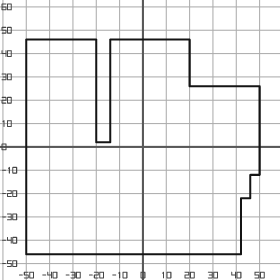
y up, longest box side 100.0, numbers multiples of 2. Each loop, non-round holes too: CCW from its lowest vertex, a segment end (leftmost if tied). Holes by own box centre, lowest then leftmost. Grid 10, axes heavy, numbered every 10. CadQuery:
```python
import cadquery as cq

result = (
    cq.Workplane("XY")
    .moveTo(-50.0, -46.0)
    .lineTo(42.0, -46.0)
    .lineTo(42.0, -22.0)
    .lineTo(46.0, -22.0)
    .lineTo(46.0, -12.0)
    .lineTo(50.0, -12.0)
    .lineTo(50.0, 26.0)
    .lineTo(20.0, 26.0)
    .lineTo(20.0, 46.0)
    .lineTo(-14.0, 46.0)
    .lineTo(-14.0, 2.0)
    .lineTo(-20.0, 2.0)
    .lineTo(-20.0, 46.0)
    .lineTo(-50.0, 46.0)
    .close()
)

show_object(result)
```